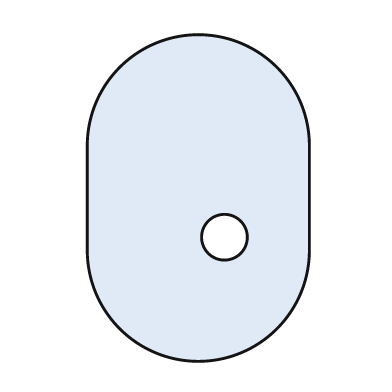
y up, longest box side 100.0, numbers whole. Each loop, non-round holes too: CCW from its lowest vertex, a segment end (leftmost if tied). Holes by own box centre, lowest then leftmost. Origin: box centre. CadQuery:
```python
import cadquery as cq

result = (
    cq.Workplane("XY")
    .moveTo(-34.0, -16.0)
    .threePointArc((0.0, -50.0), (34.0, -16.0))
    .lineTo(34.0, 16.0)
    .threePointArc((0.0, 50.0), (-34.0, 16.0))
    .close()
    .moveTo(8.0, -12.0)
    .circle(7.0)
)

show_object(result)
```